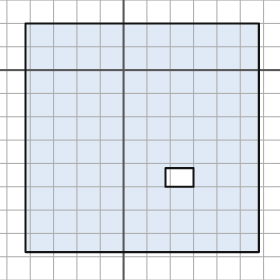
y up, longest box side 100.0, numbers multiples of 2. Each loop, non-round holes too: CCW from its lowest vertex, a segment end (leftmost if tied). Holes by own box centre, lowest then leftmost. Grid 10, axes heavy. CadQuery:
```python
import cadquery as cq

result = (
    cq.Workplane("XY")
    .moveTo(-42.0, -78.0)
    .lineTo(58.0, -78.0)
    .lineTo(58.0, 20.0)
    .lineTo(-42.0, 20.0)
    .close()
    .moveTo(18.0, -50.0)
    .lineTo(30.0, -50.0)
    .lineTo(30.0, -42.0)
    .lineTo(18.0, -42.0)
    .close()
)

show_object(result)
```